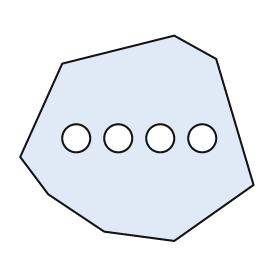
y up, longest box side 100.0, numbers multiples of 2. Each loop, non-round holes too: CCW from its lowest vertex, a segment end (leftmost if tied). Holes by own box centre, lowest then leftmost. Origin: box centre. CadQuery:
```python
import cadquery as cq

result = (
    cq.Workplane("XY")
    .moveTo(16.0, -44.0)
    .lineTo(50.0, -20.0)
    .lineTo(34.0, 34.0)
    .lineTo(16.0, 44.0)
    .lineTo(-32.0, 32.0)
    .lineTo(-50.0, -8.0)
    .lineTo(-38.0, -24.0)
    .lineTo(-14.0, -40.0)
    .close()
    .moveTo(-26.0, 0.0)
    .circle(6.0)
    .moveTo(-8.0, 0.0)
    .circle(6.0)
    .moveTo(10.0, 0.0)
    .circle(6.0)
    .moveTo(28.0, 0.0)
    .circle(6.0)
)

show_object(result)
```